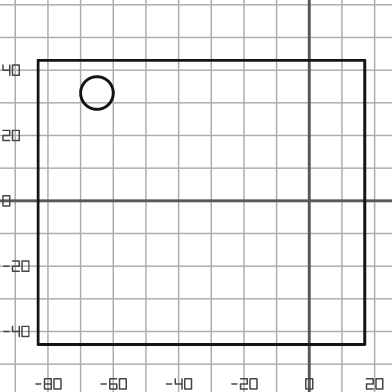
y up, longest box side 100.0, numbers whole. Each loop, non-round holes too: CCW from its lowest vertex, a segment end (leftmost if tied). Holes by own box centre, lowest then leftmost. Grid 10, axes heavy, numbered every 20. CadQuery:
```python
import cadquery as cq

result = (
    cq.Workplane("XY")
    .moveTo(-83.0, -44.0)
    .lineTo(17.0, -44.0)
    .lineTo(17.0, 43.0)
    .lineTo(-83.0, 43.0)
    .close()
    .moveTo(-65.0, 33.0)
    .circle(5.0)
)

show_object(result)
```